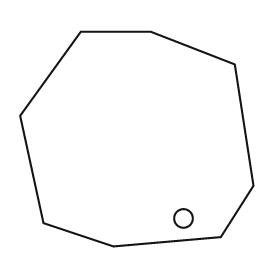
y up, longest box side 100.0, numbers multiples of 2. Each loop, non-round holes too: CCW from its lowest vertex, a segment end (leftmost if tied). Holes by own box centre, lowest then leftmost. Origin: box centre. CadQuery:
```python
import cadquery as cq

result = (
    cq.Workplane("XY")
    .moveTo(-10.0, -46.0)
    .lineTo(36.0, -42.0)
    .lineTo(50.0, -20.0)
    .lineTo(42.0, 32.0)
    .lineTo(6.0, 46.0)
    .lineTo(-24.0, 46.0)
    .lineTo(-50.0, 10.0)
    .lineTo(-40.0, -36.0)
    .close()
    .moveTo(20.0, -34.0)
    .circle(4.0)
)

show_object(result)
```